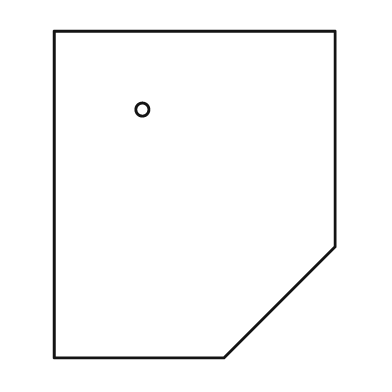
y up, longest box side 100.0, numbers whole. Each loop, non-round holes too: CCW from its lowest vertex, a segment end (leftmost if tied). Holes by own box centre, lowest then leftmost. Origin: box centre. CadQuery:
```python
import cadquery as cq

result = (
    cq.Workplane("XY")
    .moveTo(-43.0, -50.0)
    .lineTo(9.0, -50.0)
    .lineTo(43.0, -16.0)
    .lineTo(43.0, 50.0)
    .lineTo(-43.0, 50.0)
    .close()
    .moveTo(-16.0, 26.0)
    .circle(2.0)
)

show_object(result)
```